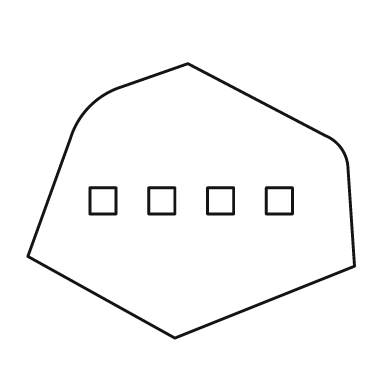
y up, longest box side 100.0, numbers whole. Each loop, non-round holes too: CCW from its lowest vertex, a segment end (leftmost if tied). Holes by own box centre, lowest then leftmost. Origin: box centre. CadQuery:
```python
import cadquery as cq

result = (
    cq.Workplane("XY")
    .moveTo(-5.0, -42.0)
    .lineTo(50.0, -20.0)
    .lineTo(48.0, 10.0)
    .threePointArc((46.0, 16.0), (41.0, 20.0))
    .lineTo(-1.0, 42.0)
    .lineTo(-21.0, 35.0)
    .threePointArc((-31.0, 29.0), (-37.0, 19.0))
    .lineTo(-50.0, -17.0)
    .close()
    .moveTo(-31.0, -4.0)
    .lineTo(-23.0, -4.0)
    .lineTo(-23.0, 4.0)
    .lineTo(-31.0, 4.0)
    .close()
    .moveTo(-13.0, -4.0)
    .lineTo(-5.0, -4.0)
    .lineTo(-5.0, 4.0)
    .lineTo(-13.0, 4.0)
    .close()
    .moveTo(5.0, -4.0)
    .lineTo(13.0, -4.0)
    .lineTo(13.0, 4.0)
    .lineTo(5.0, 4.0)
    .close()
    .moveTo(23.0, -4.0)
    .lineTo(31.0, -4.0)
    .lineTo(31.0, 4.0)
    .lineTo(23.0, 4.0)
    .close()
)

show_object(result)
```